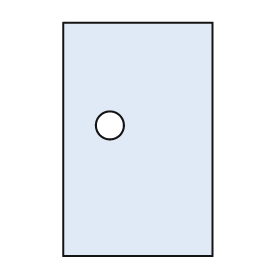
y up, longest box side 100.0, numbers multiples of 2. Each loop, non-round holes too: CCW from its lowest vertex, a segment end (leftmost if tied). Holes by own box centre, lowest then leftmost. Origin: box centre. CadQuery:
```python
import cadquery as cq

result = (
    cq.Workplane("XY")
    .moveTo(-32.0, -50.0)
    .lineTo(32.0, -50.0)
    .lineTo(32.0, 50.0)
    .lineTo(-32.0, 50.0)
    .close()
    .moveTo(-12.0, 6.0)
    .circle(6.0)
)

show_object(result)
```